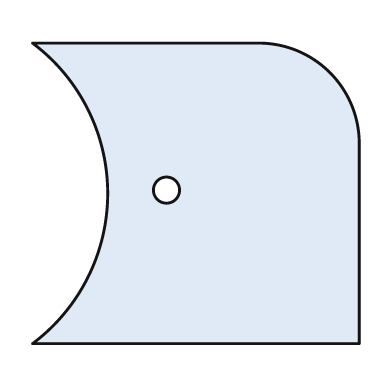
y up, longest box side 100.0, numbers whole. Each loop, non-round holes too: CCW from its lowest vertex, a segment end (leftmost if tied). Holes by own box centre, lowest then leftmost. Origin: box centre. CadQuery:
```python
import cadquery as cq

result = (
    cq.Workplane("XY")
    .moveTo(-50.0, -46.0)
    .lineTo(50.0, -46.0)
    .lineTo(50.0, 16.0)
    .threePointArc((41.0, 37.0), (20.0, 46.0))
    .lineTo(-50.0, 46.0)
    .threePointArc((-27.0, 0.0), (-50.0, -46.0))
    .close()
    .moveTo(-9.0, 1.0)
    .circle(4.0)
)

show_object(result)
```